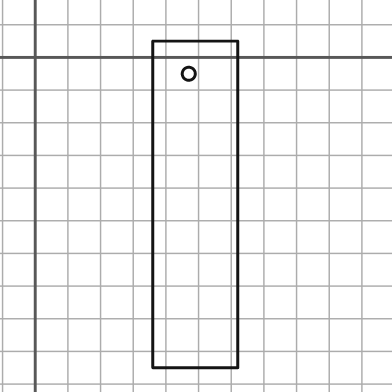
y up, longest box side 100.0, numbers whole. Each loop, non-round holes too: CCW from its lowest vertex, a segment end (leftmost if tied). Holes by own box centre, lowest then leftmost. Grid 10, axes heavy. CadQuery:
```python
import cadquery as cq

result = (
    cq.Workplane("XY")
    .moveTo(36.0, -95.0)
    .lineTo(62.0, -95.0)
    .lineTo(62.0, 5.0)
    .lineTo(36.0, 5.0)
    .close()
    .moveTo(47.0, -5.0)
    .circle(2.0)
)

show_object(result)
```